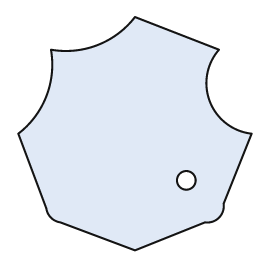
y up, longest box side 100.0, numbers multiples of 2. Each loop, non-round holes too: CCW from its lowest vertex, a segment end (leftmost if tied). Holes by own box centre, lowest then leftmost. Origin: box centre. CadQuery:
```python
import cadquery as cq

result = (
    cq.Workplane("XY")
    .moveTo(0.0, -50.0)
    .lineTo(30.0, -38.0)
    .threePointArc((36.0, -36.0), (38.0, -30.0))
    .lineTo(50.0, 0.0)
    .threePointArc((32.0, 14.0), (36.0, 36.0))
    .lineTo(0.0, 50.0)
    .threePointArc((-16.0, 38.0), (-36.0, 36.0))
    .threePointArc((-38.0, 16.0), (-50.0, 0.0))
    .lineTo(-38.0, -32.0)
    .threePointArc((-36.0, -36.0), (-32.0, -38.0))
    .close()
    .moveTo(22.0, -20.0)
    .circle(4.0)
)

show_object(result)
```